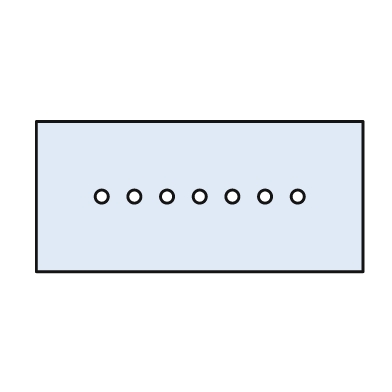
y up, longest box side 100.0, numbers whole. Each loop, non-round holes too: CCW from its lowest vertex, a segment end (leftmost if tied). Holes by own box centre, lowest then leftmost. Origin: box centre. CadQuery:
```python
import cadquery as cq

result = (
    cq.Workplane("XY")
    .moveTo(-50.0, -23.0)
    .lineTo(50.0, -23.0)
    .lineTo(50.0, 23.0)
    .lineTo(-50.0, 23.0)
    .close()
    .moveTo(-30.0, 0.0)
    .circle(2.0)
    .moveTo(-20.0, 0.0)
    .circle(2.0)
    .moveTo(-10.0, 0.0)
    .circle(2.0)
    .moveTo(0.0, 0.0)
    .circle(2.0)
    .moveTo(10.0, 0.0)
    .circle(2.0)
    .moveTo(20.0, 0.0)
    .circle(2.0)
    .moveTo(30.0, 0.0)
    .circle(2.0)
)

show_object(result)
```